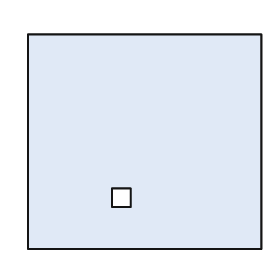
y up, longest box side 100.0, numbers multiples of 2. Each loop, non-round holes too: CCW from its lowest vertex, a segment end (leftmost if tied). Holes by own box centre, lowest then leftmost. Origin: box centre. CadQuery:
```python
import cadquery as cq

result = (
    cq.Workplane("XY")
    .moveTo(-50.0, -46.0)
    .lineTo(50.0, -46.0)
    .lineTo(50.0, 46.0)
    .lineTo(-50.0, 46.0)
    .close()
    .moveTo(-14.0, -28.0)
    .lineTo(-6.0, -28.0)
    .lineTo(-6.0, -20.0)
    .lineTo(-14.0, -20.0)
    .close()
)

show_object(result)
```